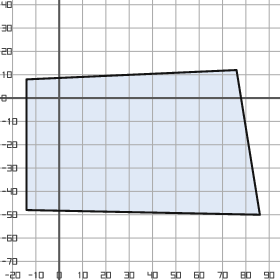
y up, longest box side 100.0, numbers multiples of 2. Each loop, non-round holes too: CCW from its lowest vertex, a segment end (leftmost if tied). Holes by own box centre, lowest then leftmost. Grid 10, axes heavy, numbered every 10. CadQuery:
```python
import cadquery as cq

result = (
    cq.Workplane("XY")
    .moveTo(86.0, -50.0)
    .lineTo(76.0, 12.0)
    .lineTo(-14.0, 8.0)
    .lineTo(-14.0, -48.0)
    .close()
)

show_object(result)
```